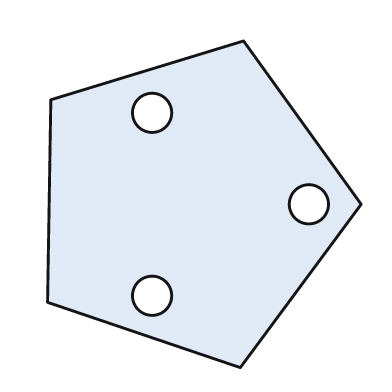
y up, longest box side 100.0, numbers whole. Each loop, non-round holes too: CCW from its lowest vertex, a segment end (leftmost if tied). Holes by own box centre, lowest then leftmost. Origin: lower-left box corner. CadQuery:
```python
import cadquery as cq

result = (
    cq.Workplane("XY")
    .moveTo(59.0, 0.0)
    .lineTo(96.0, 50.0)
    .lineTo(60.0, 100.0)
    .lineTo(1.0, 82.0)
    .lineTo(0.0, 20.0)
    .close()
    .moveTo(32.0, 22.0)
    .circle(6.0)
    .moveTo(80.0, 50.0)
    .circle(6.0)
    .moveTo(32.0, 78.0)
    .circle(6.0)
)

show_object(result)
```